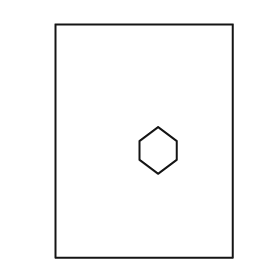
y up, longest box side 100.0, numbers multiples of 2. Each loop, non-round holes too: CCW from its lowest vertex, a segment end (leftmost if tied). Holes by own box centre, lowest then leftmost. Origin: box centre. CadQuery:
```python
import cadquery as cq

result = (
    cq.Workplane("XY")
    .moveTo(-38.0, -50.0)
    .lineTo(38.0, -50.0)
    .lineTo(38.0, 50.0)
    .lineTo(-38.0, 50.0)
    .close()
    .moveTo(6.0, -14.0)
    .lineTo(14.0, -8.0)
    .lineTo(14.0, 0.0)
    .lineTo(6.0, 6.0)
    .lineTo(-2.0, 0.0)
    .lineTo(-2.0, -8.0)
    .close()
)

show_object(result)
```